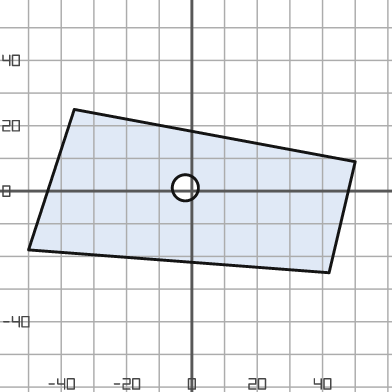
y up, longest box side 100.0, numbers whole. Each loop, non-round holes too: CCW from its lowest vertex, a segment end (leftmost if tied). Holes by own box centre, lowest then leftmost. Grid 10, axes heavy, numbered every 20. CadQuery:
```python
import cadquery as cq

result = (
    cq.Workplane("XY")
    .moveTo(42.0, -25.0)
    .lineTo(50.0, 9.0)
    .lineTo(-36.0, 25.0)
    .lineTo(-50.0, -18.0)
    .close()
    .moveTo(-2.0, 1.0)
    .circle(4.0)
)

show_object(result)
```